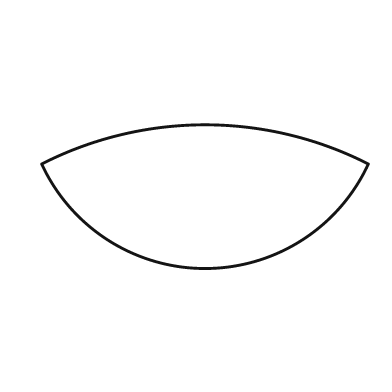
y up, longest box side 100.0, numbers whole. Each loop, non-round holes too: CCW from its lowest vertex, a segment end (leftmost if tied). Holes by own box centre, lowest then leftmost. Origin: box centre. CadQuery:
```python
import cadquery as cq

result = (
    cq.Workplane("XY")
    .moveTo(-50.0, 10.0)
    .threePointArc((0.0, -22.0), (50.0, 10.0))
    .threePointArc((0.0, 22.0), (-50.0, 10.0))
    .close()
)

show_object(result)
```